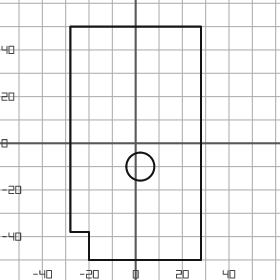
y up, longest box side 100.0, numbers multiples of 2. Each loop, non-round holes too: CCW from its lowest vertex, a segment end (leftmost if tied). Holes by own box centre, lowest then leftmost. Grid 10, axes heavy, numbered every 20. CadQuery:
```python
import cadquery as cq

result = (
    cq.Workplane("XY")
    .moveTo(-20.0, -50.0)
    .lineTo(28.0, -50.0)
    .lineTo(28.0, 50.0)
    .lineTo(-28.0, 50.0)
    .lineTo(-28.0, -38.0)
    .lineTo(-20.0, -38.0)
    .close()
    .moveTo(2.0, -10.0)
    .circle(6.0)
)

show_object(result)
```